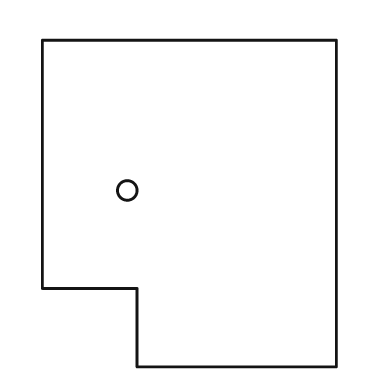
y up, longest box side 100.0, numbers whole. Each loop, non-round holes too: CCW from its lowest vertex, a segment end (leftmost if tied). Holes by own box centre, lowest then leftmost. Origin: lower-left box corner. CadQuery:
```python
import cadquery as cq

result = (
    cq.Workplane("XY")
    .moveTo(29.0, 0.0)
    .lineTo(90.0, 0.0)
    .lineTo(90.0, 100.0)
    .lineTo(0.0, 100.0)
    .lineTo(0.0, 24.0)
    .lineTo(29.0, 24.0)
    .close()
    .moveTo(26.0, 54.0)
    .circle(3.0)
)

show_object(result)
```